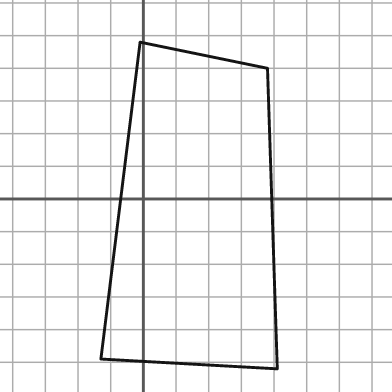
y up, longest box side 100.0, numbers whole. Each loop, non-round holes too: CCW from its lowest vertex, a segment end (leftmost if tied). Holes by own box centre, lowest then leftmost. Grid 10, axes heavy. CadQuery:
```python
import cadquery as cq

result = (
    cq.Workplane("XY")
    .moveTo(41.0, -52.0)
    .lineTo(38.0, 40.0)
    .lineTo(-1.0, 48.0)
    .lineTo(-13.0, -49.0)
    .close()
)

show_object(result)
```